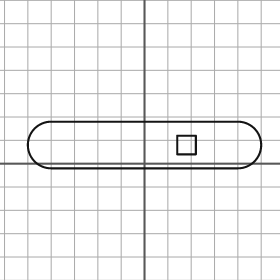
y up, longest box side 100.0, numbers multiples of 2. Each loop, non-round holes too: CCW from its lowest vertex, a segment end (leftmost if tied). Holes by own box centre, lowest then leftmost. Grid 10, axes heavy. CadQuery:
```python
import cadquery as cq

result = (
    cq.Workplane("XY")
    .moveTo(-40.0, -2.0)
    .lineTo(40.0, -2.0)
    .threePointArc((50.0, 8.0), (40.0, 18.0))
    .lineTo(-40.0, 18.0)
    .threePointArc((-50.0, 8.0), (-40.0, -2.0))
    .close()
    .moveTo(14.0, 4.0)
    .lineTo(22.0, 4.0)
    .lineTo(22.0, 12.0)
    .lineTo(14.0, 12.0)
    .close()
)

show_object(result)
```